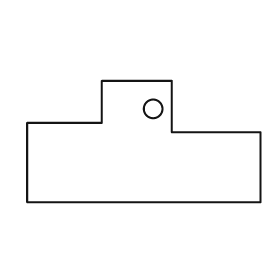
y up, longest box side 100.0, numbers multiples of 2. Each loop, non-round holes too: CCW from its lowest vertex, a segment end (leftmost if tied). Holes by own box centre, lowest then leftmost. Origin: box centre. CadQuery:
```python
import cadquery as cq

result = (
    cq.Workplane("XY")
    .moveTo(-50.0, -26.0)
    .lineTo(50.0, -26.0)
    .lineTo(50.0, 4.0)
    .lineTo(12.0, 4.0)
    .lineTo(12.0, 26.0)
    .lineTo(-18.0, 26.0)
    .lineTo(-18.0, 8.0)
    .lineTo(-50.0, 8.0)
    .close()
    .moveTo(4.0, 14.0)
    .circle(4.0)
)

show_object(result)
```